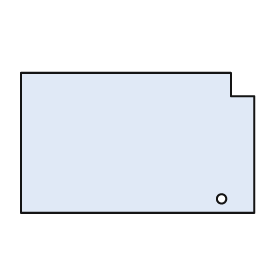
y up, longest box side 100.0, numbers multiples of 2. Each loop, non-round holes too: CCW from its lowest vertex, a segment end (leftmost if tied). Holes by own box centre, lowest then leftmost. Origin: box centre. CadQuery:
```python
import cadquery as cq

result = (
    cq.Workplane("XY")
    .moveTo(-50.0, -30.0)
    .lineTo(50.0, -30.0)
    .lineTo(50.0, 20.0)
    .lineTo(40.0, 20.0)
    .lineTo(40.0, 30.0)
    .lineTo(-50.0, 30.0)
    .close()
    .moveTo(36.0, -24.0)
    .circle(2.0)
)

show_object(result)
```